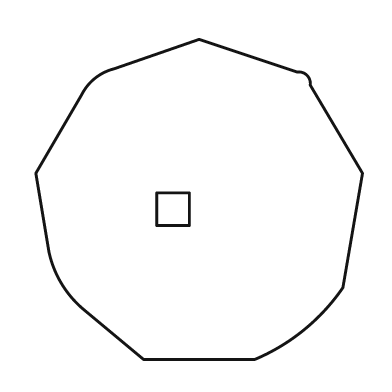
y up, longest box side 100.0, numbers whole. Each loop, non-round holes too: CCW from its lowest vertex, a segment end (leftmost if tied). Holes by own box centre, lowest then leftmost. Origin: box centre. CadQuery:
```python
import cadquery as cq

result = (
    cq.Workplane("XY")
    .moveTo(-17.0, -49.0)
    .lineTo(17.0, -49.0)
    .threePointArc((32.0, -40.0), (44.0, -27.0))
    .lineTo(50.0, 8.0)
    .lineTo(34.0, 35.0)
    .threePointArc((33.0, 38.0), (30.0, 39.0))
    .lineTo(0.0, 49.0)
    .lineTo(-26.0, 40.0)
    .threePointArc((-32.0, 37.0), (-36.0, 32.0))
    .lineTo(-50.0, 8.0)
    .lineTo(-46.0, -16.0)
    .threePointArc((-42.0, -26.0), (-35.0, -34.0))
    .close()
    .moveTo(-13.0, -8.0)
    .lineTo(-3.0, -8.0)
    .lineTo(-3.0, 2.0)
    .lineTo(-13.0, 2.0)
    .close()
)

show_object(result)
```